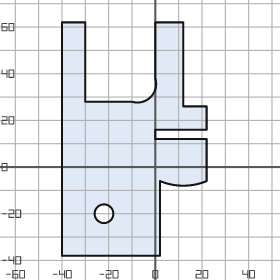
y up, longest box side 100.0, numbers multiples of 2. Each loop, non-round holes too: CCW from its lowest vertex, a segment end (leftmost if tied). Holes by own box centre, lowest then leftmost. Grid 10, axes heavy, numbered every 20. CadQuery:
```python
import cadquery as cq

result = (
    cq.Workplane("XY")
    .moveTo(-40.0, -38.0)
    .lineTo(2.0, -38.0)
    .lineTo(2.0, -6.0)
    .threePointArc((12.0, -8.0), (22.0, -6.0))
    .lineTo(22.0, 12.0)
    .lineTo(0.0, 12.0)
    .lineTo(0.0, 16.0)
    .lineTo(22.0, 16.0)
    .lineTo(22.0, 26.0)
    .lineTo(12.0, 26.0)
    .lineTo(12.0, 62.0)
    .lineTo(0.0, 62.0)
    .lineTo(0.0, 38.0)
    .threePointArc((-2.0, 30.0), (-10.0, 28.0))
    .lineTo(-30.0, 28.0)
    .lineTo(-30.0, 62.0)
    .lineTo(-40.0, 62.0)
    .close()
    .moveTo(-22.0, -20.0)
    .circle(4.0)
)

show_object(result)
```